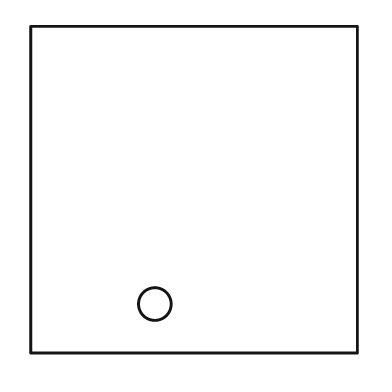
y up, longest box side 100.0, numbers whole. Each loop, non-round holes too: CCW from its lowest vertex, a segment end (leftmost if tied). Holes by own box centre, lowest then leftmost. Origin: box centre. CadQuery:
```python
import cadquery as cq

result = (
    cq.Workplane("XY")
    .moveTo(-50.0, -50.0)
    .lineTo(50.0, -50.0)
    .lineTo(50.0, 50.0)
    .lineTo(-50.0, 50.0)
    .close()
    .moveTo(-12.0, -35.0)
    .circle(5.0)
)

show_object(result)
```